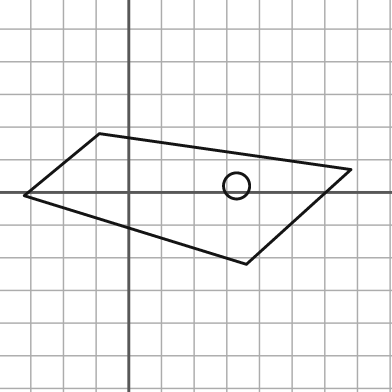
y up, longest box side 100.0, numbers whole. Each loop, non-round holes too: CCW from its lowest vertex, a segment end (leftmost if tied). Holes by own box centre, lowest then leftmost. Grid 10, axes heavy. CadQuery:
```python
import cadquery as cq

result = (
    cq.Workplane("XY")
    .moveTo(36.0, -22.0)
    .lineTo(68.0, 7.0)
    .lineTo(-9.0, 18.0)
    .lineTo(-32.0, -1.0)
    .close()
    .moveTo(33.0, 2.0)
    .circle(4.0)
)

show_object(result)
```